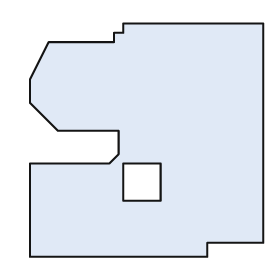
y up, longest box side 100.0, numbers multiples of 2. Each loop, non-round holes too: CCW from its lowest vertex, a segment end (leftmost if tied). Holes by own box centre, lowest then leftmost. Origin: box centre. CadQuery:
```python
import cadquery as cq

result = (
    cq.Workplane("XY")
    .moveTo(-50.0, -50.0)
    .lineTo(26.0, -50.0)
    .lineTo(26.0, -44.0)
    .lineTo(50.0, -44.0)
    .lineTo(50.0, 50.0)
    .lineTo(-10.0, 50.0)
    .lineTo(-10.0, 46.0)
    .lineTo(-14.0, 46.0)
    .lineTo(-14.0, 42.0)
    .lineTo(-42.0, 42.0)
    .lineTo(-50.0, 26.0)
    .lineTo(-50.0, 16.0)
    .lineTo(-38.0, 4.0)
    .lineTo(-12.0, 4.0)
    .lineTo(-12.0, -6.0)
    .lineTo(-16.0, -10.0)
    .lineTo(-50.0, -10.0)
    .close()
    .moveTo(-10.0, -26.0)
    .lineTo(6.0, -26.0)
    .lineTo(6.0, -10.0)
    .lineTo(-10.0, -10.0)
    .close()
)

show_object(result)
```